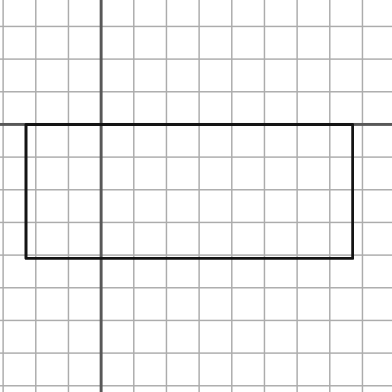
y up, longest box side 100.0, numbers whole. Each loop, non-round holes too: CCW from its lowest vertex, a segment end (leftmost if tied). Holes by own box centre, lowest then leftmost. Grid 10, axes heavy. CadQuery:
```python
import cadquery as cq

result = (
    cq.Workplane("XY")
    .moveTo(-23.0, -41.0)
    .lineTo(77.0, -41.0)
    .lineTo(77.0, 0.0)
    .lineTo(-23.0, 0.0)
    .close()
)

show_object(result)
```